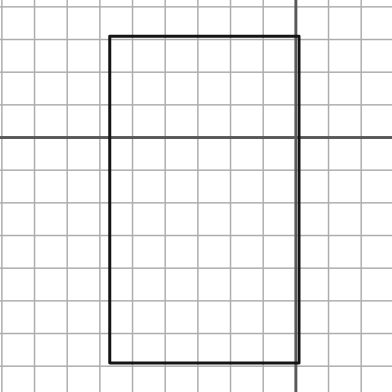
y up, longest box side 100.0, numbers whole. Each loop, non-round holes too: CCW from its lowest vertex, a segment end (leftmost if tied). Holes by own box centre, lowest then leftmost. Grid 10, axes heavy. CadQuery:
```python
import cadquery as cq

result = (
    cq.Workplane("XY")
    .moveTo(-57.0, -69.0)
    .lineTo(1.0, -69.0)
    .lineTo(1.0, 31.0)
    .lineTo(-57.0, 31.0)
    .close()
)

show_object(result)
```